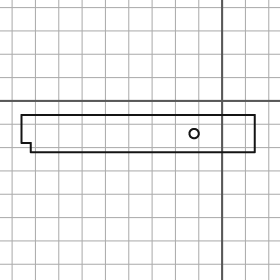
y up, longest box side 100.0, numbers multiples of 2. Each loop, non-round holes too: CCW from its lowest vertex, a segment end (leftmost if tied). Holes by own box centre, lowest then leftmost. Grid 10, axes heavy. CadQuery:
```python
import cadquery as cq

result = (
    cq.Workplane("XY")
    .moveTo(-82.0, -22.0)
    .lineTo(14.0, -22.0)
    .lineTo(14.0, -6.0)
    .lineTo(-86.0, -6.0)
    .lineTo(-86.0, -18.0)
    .lineTo(-82.0, -18.0)
    .close()
    .moveTo(-12.0, -14.0)
    .circle(2.0)
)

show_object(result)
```